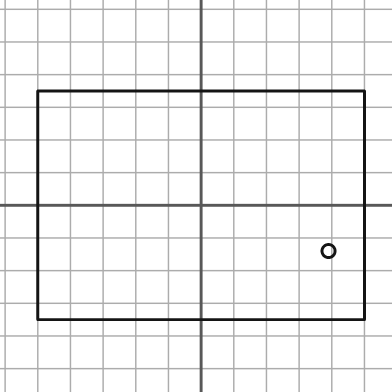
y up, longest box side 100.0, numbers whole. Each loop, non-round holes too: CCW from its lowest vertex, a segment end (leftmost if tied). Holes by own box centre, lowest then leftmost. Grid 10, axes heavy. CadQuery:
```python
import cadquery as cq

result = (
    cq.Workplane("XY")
    .moveTo(-50.0, -35.0)
    .lineTo(50.0, -35.0)
    .lineTo(50.0, 35.0)
    .lineTo(-50.0, 35.0)
    .close()
    .moveTo(39.0, -14.0)
    .circle(2.0)
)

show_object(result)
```